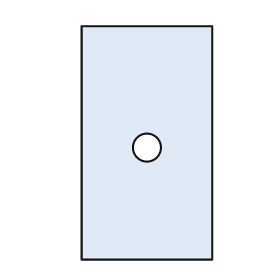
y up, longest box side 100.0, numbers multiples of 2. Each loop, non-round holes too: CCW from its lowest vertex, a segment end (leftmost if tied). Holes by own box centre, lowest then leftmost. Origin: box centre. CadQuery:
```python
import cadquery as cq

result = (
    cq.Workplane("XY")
    .moveTo(-28.0, -50.0)
    .lineTo(28.0, -50.0)
    .lineTo(28.0, 50.0)
    .lineTo(-28.0, 50.0)
    .close()
    .moveTo(0.0, -2.0)
    .circle(6.0)
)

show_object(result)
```